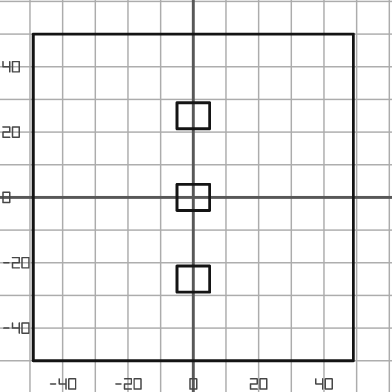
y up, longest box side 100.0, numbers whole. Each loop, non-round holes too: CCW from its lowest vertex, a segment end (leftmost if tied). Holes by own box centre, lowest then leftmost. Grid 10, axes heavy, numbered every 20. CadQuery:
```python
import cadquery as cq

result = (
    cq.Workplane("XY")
    .moveTo(-49.0, -50.0)
    .lineTo(49.0, -50.0)
    .lineTo(49.0, 50.0)
    .lineTo(-49.0, 50.0)
    .close()
    .moveTo(-5.0, -29.0)
    .lineTo(5.0, -29.0)
    .lineTo(5.0, -21.0)
    .lineTo(-5.0, -21.0)
    .close()
    .moveTo(-5.0, -4.0)
    .lineTo(5.0, -4.0)
    .lineTo(5.0, 4.0)
    .lineTo(-5.0, 4.0)
    .close()
    .moveTo(-5.0, 21.0)
    .lineTo(5.0, 21.0)
    .lineTo(5.0, 29.0)
    .lineTo(-5.0, 29.0)
    .close()
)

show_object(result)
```